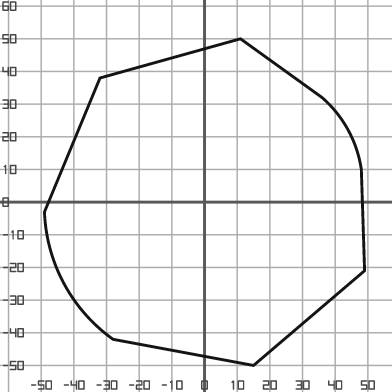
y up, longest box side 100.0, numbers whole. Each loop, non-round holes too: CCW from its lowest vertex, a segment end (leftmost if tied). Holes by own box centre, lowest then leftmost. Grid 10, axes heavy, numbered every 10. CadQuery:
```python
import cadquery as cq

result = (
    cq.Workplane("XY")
    .moveTo(15.0, -50.0)
    .lineTo(49.0, -21.0)
    .lineTo(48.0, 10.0)
    .threePointArc((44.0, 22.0), (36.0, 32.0))
    .lineTo(11.0, 50.0)
    .lineTo(-32.0, 38.0)
    .lineTo(-49.0, -3.0)
    .threePointArc((-43.0, -25.0), (-28.0, -42.0))
    .close()
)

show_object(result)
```